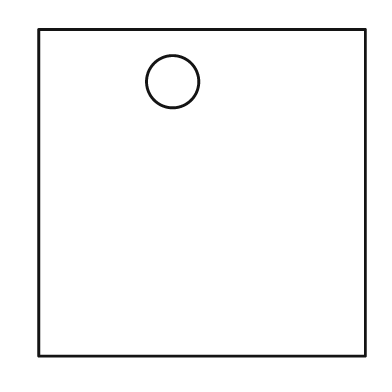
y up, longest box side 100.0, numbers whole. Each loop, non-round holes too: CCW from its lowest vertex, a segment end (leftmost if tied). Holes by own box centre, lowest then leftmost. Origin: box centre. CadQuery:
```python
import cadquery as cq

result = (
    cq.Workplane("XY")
    .moveTo(-50.0, -50.0)
    .lineTo(50.0, -50.0)
    .lineTo(50.0, 50.0)
    .lineTo(-50.0, 50.0)
    .close()
    .moveTo(-9.0, 34.0)
    .circle(8.0)
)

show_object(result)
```